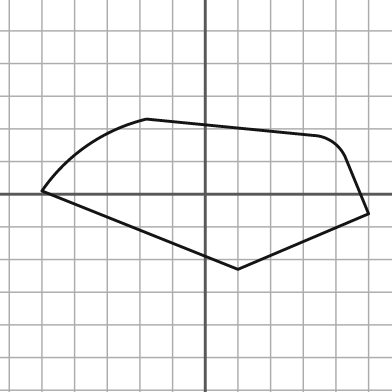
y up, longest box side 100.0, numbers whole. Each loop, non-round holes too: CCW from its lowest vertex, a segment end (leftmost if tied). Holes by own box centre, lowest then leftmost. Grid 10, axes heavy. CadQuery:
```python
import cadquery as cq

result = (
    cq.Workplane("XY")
    .moveTo(10.0, -23.0)
    .lineTo(50.0, -6.0)
    .lineTo(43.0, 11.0)
    .threePointArc((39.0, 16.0), (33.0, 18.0))
    .lineTo(-18.0, 23.0)
    .threePointArc((-36.0, 15.0), (-50.0, 1.0))
    .close()
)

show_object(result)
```